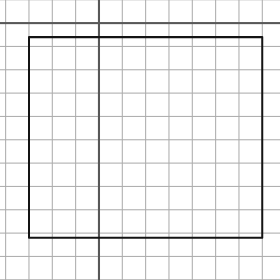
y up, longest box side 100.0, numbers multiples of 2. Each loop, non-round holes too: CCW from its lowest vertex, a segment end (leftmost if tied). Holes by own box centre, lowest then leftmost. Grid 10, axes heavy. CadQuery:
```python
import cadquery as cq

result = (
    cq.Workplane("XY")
    .moveTo(-30.0, -92.0)
    .lineTo(70.0, -92.0)
    .lineTo(70.0, -6.0)
    .lineTo(-30.0, -6.0)
    .close()
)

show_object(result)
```